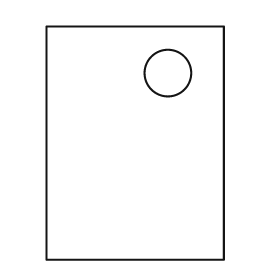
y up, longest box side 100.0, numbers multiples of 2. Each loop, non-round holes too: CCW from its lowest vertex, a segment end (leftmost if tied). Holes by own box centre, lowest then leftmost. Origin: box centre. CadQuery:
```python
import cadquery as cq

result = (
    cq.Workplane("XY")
    .moveTo(-38.0, -50.0)
    .lineTo(38.0, -50.0)
    .lineTo(38.0, 50.0)
    .lineTo(-38.0, 50.0)
    .close()
    .moveTo(14.0, 30.0)
    .circle(10.0)
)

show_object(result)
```